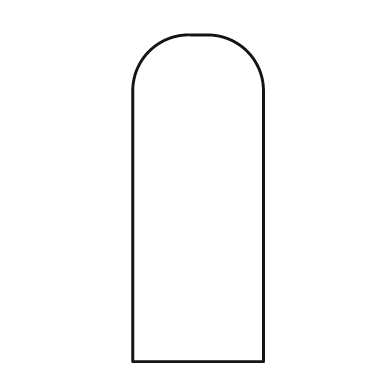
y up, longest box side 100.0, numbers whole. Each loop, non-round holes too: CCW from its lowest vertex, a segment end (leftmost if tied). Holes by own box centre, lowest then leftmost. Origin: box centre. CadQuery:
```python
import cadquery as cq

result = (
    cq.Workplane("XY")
    .moveTo(-20.0, -50.0)
    .lineTo(20.0, -50.0)
    .lineTo(20.0, 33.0)
    .threePointArc((15.0, 45.0), (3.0, 50.0))
    .lineTo(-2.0, 50.0)
    .threePointArc((-15.0, 45.0), (-20.0, 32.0))
    .close()
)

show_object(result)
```